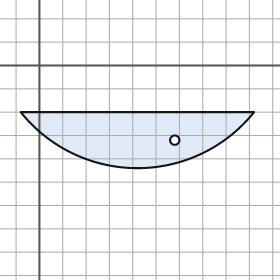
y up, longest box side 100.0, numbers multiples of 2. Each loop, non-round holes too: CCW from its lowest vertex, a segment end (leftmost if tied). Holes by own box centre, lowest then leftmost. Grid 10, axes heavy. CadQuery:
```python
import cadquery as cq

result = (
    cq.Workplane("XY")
    .moveTo(-8.0, -20.0)
    .threePointArc((42.0, -44.0), (92.0, -20.0))
    .close()
    .moveTo(58.0, -32.0)
    .circle(2.0)
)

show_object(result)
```